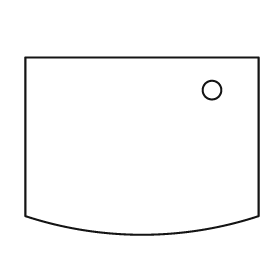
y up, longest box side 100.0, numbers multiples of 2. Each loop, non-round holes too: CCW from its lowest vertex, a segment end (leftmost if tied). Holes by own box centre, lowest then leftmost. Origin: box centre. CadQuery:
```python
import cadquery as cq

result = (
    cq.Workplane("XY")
    .moveTo(-50.0, -30.0)
    .threePointArc((0.0, -38.0), (50.0, -30.0))
    .lineTo(50.0, 38.0)
    .lineTo(-50.0, 38.0)
    .close()
    .moveTo(30.0, 24.0)
    .circle(4.0)
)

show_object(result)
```